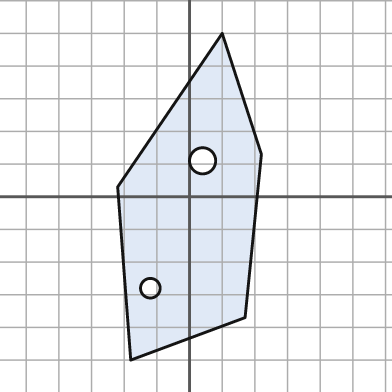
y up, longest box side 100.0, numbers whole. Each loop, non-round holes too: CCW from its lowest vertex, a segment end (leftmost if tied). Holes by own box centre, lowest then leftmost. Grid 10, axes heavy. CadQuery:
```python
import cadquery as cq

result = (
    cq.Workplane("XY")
    .moveTo(-18.0, -50.0)
    .lineTo(17.0, -37.0)
    .lineTo(22.0, 13.0)
    .lineTo(10.0, 50.0)
    .lineTo(-22.0, 3.0)
    .close()
    .moveTo(-12.0, -28.0)
    .circle(3.0)
    .moveTo(4.0, 11.0)
    .circle(4.0)
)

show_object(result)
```